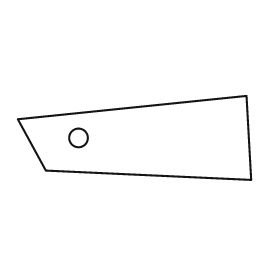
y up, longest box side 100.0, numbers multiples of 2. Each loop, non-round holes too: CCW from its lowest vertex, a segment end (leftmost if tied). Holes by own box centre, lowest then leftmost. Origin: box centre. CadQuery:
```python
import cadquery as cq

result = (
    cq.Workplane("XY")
    .moveTo(50.0, -18.0)
    .lineTo(48.0, 18.0)
    .lineTo(-50.0, 8.0)
    .lineTo(-38.0, -14.0)
    .close()
    .moveTo(-24.0, 0.0)
    .circle(4.0)
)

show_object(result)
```